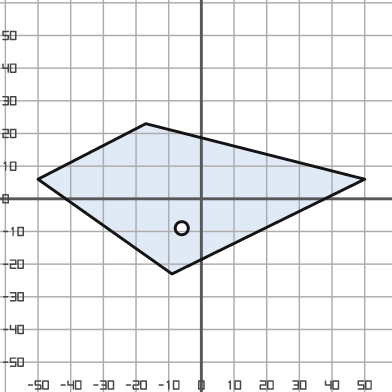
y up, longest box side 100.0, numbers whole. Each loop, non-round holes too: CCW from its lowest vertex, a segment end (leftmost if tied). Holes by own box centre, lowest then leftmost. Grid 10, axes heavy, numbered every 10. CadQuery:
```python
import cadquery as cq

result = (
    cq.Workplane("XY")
    .moveTo(-9.0, -23.0)
    .lineTo(50.0, 6.0)
    .lineTo(-17.0, 23.0)
    .lineTo(-50.0, 6.0)
    .close()
    .moveTo(-6.0, -9.0)
    .circle(2.0)
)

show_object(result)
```